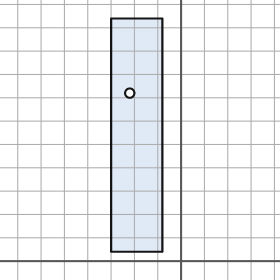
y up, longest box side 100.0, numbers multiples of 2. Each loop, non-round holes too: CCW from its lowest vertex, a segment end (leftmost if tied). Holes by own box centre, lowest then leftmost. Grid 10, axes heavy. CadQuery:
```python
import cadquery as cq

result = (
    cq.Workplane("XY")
    .moveTo(-30.0, 4.0)
    .lineTo(-8.0, 4.0)
    .lineTo(-8.0, 104.0)
    .lineTo(-30.0, 104.0)
    .close()
    .moveTo(-22.0, 72.0)
    .circle(2.0)
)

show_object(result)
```